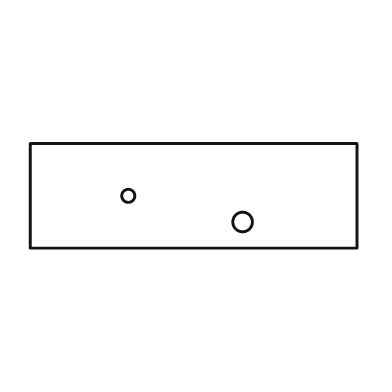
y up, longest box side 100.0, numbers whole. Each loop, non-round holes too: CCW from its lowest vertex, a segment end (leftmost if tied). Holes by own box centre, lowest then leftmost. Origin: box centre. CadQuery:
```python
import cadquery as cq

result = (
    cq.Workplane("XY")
    .moveTo(-50.0, -16.0)
    .lineTo(50.0, -16.0)
    .lineTo(50.0, 16.0)
    .lineTo(-50.0, 16.0)
    .close()
    .moveTo(15.0, -8.0)
    .circle(3.0)
    .moveTo(-20.0, 0.0)
    .circle(2.0)
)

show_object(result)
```